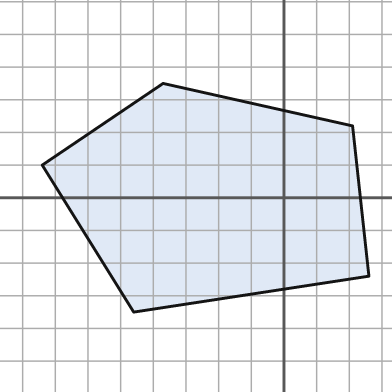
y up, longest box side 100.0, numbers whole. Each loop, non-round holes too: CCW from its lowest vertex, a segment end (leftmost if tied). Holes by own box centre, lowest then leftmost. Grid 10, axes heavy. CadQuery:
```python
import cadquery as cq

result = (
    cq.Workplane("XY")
    .moveTo(-46.0, -35.0)
    .lineTo(26.0, -24.0)
    .lineTo(21.0, 22.0)
    .lineTo(-37.0, 35.0)
    .lineTo(-74.0, 10.0)
    .close()
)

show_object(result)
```